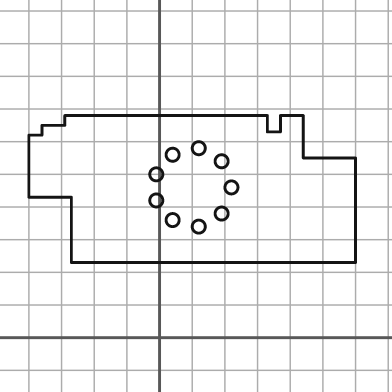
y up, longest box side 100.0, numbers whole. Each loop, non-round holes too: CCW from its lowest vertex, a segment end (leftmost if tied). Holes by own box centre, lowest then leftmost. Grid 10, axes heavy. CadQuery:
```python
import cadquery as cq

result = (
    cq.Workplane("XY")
    .moveTo(-27.0, 23.0)
    .lineTo(60.0, 23.0)
    .lineTo(60.0, 55.0)
    .lineTo(44.0, 55.0)
    .lineTo(44.0, 68.0)
    .lineTo(37.0, 68.0)
    .lineTo(37.0, 63.0)
    .lineTo(33.0, 63.0)
    .lineTo(33.0, 68.0)
    .lineTo(-29.0, 68.0)
    .lineTo(-29.0, 65.0)
    .lineTo(-36.0, 65.0)
    .lineTo(-36.0, 62.0)
    .lineTo(-40.0, 62.0)
    .lineTo(-40.0, 43.0)
    .lineTo(-27.0, 43.0)
    .close()
    .moveTo(12.0, 34.0)
    .circle(2.0)
    .moveTo(4.0, 36.0)
    .circle(2.0)
    .moveTo(19.0, 38.0)
    .circle(2.0)
    .moveTo(-1.0, 42.0)
    .circle(2.0)
    .moveTo(22.0, 46.0)
    .circle(2.0)
    .moveTo(-1.0, 50.0)
    .circle(2.0)
    .moveTo(19.0, 54.0)
    .circle(2.0)
    .moveTo(4.0, 56.0)
    .circle(2.0)
    .moveTo(12.0, 58.0)
    .circle(2.0)
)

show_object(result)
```